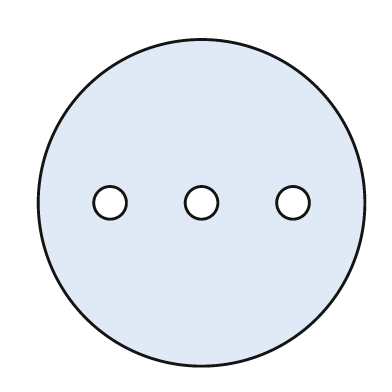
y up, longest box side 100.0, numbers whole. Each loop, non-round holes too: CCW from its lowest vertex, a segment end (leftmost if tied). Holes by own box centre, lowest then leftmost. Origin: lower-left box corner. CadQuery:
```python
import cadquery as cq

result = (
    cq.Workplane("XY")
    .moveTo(50.0, 50.0)
    .circle(50.0)
    .moveTo(22.0, 50.0)
    .circle(5.0)
    .moveTo(50.0, 50.0)
    .circle(5.0)
    .moveTo(78.0, 50.0)
    .circle(5.0)
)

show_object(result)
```